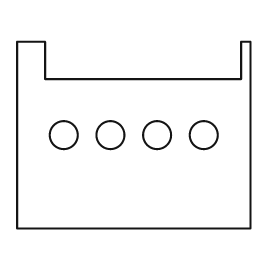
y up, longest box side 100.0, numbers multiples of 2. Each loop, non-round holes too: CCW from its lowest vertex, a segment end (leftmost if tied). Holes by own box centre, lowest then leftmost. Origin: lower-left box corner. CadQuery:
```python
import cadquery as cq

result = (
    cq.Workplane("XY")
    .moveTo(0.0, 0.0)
    .lineTo(100.0, 0.0)
    .lineTo(100.0, 80.0)
    .lineTo(96.0, 80.0)
    .lineTo(96.0, 64.0)
    .lineTo(12.0, 64.0)
    .lineTo(12.0, 80.0)
    .lineTo(0.0, 80.0)
    .close()
    .moveTo(20.0, 40.0)
    .circle(6.0)
    .moveTo(40.0, 40.0)
    .circle(6.0)
    .moveTo(60.0, 40.0)
    .circle(6.0)
    .moveTo(80.0, 40.0)
    .circle(6.0)
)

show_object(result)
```